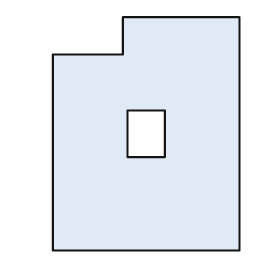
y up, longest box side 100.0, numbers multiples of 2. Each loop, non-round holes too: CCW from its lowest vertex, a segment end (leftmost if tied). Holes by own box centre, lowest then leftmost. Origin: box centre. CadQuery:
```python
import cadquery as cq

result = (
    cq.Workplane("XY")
    .moveTo(-40.0, -50.0)
    .lineTo(40.0, -50.0)
    .lineTo(40.0, 50.0)
    .lineTo(-10.0, 50.0)
    .lineTo(-10.0, 34.0)
    .lineTo(-40.0, 34.0)
    .close()
    .moveTo(-8.0, -10.0)
    .lineTo(8.0, -10.0)
    .lineTo(8.0, 10.0)
    .lineTo(-8.0, 10.0)
    .close()
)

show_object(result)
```